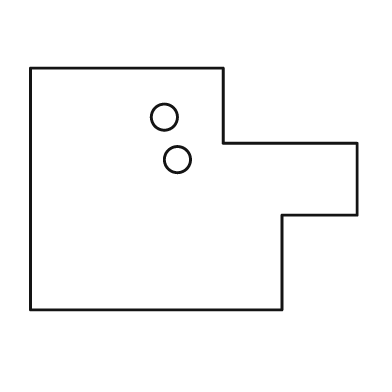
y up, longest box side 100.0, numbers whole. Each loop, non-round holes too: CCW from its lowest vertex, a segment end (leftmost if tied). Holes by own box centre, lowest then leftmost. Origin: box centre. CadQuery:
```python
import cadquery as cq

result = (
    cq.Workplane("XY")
    .moveTo(-50.0, -37.0)
    .lineTo(27.0, -37.0)
    .lineTo(27.0, -8.0)
    .lineTo(50.0, -8.0)
    .lineTo(50.0, 14.0)
    .lineTo(9.0, 14.0)
    .lineTo(9.0, 37.0)
    .lineTo(-50.0, 37.0)
    .close()
    .moveTo(-5.0, 9.0)
    .circle(4.0)
    .moveTo(-9.0, 22.0)
    .circle(4.0)
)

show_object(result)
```